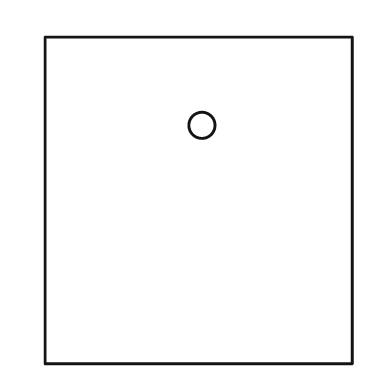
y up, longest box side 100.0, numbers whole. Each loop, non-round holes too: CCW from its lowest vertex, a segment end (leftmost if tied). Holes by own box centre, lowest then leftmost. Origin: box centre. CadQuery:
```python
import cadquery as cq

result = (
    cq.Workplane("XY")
    .moveTo(-47.0, -50.0)
    .lineTo(47.0, -50.0)
    .lineTo(47.0, 50.0)
    .lineTo(-47.0, 50.0)
    .close()
    .moveTo(1.0, 23.0)
    .circle(4.0)
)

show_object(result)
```